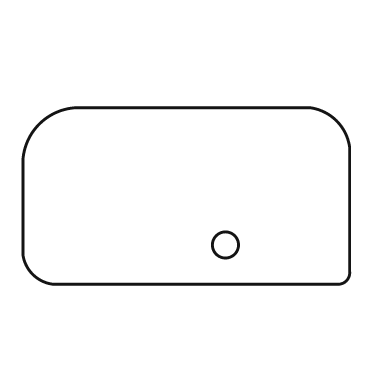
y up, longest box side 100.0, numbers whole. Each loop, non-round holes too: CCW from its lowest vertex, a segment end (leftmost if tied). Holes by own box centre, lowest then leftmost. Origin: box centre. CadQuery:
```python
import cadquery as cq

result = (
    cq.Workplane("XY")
    .moveTo(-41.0, -27.0)
    .lineTo(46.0, -27.0)
    .threePointArc((49.0, -26.0), (50.0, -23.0))
    .lineTo(50.0, 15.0)
    .threePointArc((46.0, 23.0), (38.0, 27.0))
    .lineTo(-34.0, 27.0)
    .threePointArc((-45.0, 22.0), (-50.0, 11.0))
    .lineTo(-50.0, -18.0)
    .threePointArc((-47.0, -24.0), (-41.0, -27.0))
    .close()
    .moveTo(12.0, -15.0)
    .circle(4.0)
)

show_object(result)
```